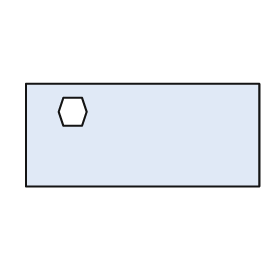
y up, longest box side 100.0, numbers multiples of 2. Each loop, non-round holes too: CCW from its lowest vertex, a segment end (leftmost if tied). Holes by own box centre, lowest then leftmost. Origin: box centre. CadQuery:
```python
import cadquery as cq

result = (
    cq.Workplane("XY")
    .moveTo(-50.0, -22.0)
    .lineTo(50.0, -22.0)
    .lineTo(50.0, 22.0)
    .lineTo(-50.0, 22.0)
    .close()
    .moveTo(-34.0, 4.0)
    .lineTo(-26.0, 4.0)
    .lineTo(-24.0, 10.0)
    .lineTo(-26.0, 16.0)
    .lineTo(-34.0, 16.0)
    .lineTo(-36.0, 10.0)
    .close()
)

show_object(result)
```